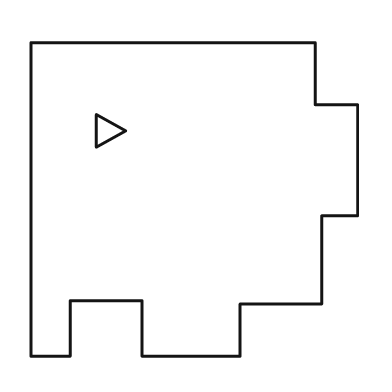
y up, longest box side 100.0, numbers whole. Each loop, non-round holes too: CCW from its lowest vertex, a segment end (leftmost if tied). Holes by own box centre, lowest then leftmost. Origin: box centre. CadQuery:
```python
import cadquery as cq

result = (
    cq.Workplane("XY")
    .moveTo(-50.0, -48.0)
    .lineTo(-38.0, -48.0)
    .lineTo(-38.0, -31.0)
    .lineTo(-16.0, -31.0)
    .lineTo(-16.0, -48.0)
    .lineTo(14.0, -48.0)
    .lineTo(14.0, -32.0)
    .lineTo(39.0, -32.0)
    .lineTo(39.0, -5.0)
    .lineTo(50.0, -5.0)
    .lineTo(50.0, 29.0)
    .lineTo(37.0, 29.0)
    .lineTo(37.0, 48.0)
    .lineTo(-50.0, 48.0)
    .close()
    .moveTo(-30.0, 16.0)
    .lineTo(-21.0, 21.0)
    .lineTo(-30.0, 26.0)
    .close()
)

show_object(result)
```